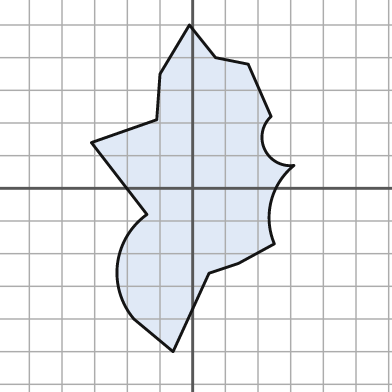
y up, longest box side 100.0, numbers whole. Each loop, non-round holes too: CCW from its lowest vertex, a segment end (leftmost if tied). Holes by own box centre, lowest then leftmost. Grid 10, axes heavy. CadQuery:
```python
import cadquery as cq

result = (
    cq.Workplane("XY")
    .moveTo(-6.0, -50.0)
    .lineTo(5.0, -26.0)
    .lineTo(14.0, -23.0)
    .lineTo(25.0, -17.0)
    .threePointArc((24.0, -4.0), (31.0, 7.0))
    .threePointArc((22.0, 12.0), (24.0, 22.0))
    .lineTo(17.0, 38.0)
    .lineTo(7.0, 40.0)
    .lineTo(-1.0, 50.0)
    .lineTo(-10.0, 35.0)
    .lineTo(-11.0, 21.0)
    .lineTo(-31.0, 14.0)
    .lineTo(-14.0, -8.0)
    .threePointArc((-23.0, -23.0), (-18.0, -40.0))
    .close()
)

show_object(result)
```